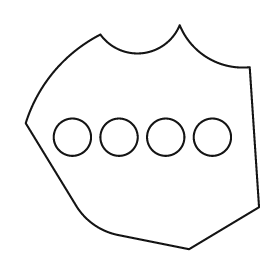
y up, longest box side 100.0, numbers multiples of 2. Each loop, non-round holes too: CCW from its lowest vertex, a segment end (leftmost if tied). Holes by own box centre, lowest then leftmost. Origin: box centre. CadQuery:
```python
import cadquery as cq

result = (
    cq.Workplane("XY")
    .moveTo(20.0, -48.0)
    .lineTo(50.0, -30.0)
    .lineTo(46.0, 30.0)
    .threePointArc((28.0, 34.0), (16.0, 48.0))
    .threePointArc((0.0, 36.0), (-18.0, 44.0))
    .threePointArc((-38.0, 28.0), (-50.0, 6.0))
    .lineTo(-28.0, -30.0)
    .threePointArc((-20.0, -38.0), (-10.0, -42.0))
    .close()
    .moveTo(-30.0, 0.0)
    .circle(8.0)
    .moveTo(-10.0, 0.0)
    .circle(8.0)
    .moveTo(10.0, 0.0)
    .circle(8.0)
    .moveTo(30.0, 0.0)
    .circle(8.0)
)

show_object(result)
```